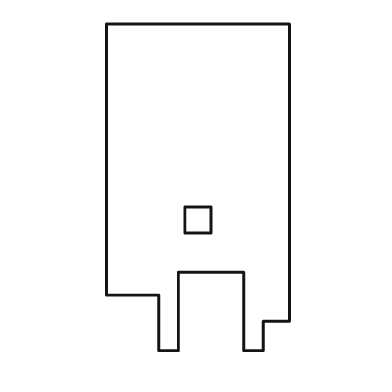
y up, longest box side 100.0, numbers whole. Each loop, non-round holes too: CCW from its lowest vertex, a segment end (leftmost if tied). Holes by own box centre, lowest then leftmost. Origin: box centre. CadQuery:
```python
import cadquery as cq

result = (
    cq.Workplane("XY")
    .moveTo(-12.0, -50.0)
    .lineTo(-6.0, -50.0)
    .lineTo(-6.0, -26.0)
    .lineTo(14.0, -26.0)
    .lineTo(14.0, -50.0)
    .lineTo(20.0, -50.0)
    .lineTo(20.0, -41.0)
    .lineTo(28.0, -41.0)
    .lineTo(28.0, 50.0)
    .lineTo(-28.0, 50.0)
    .lineTo(-28.0, -33.0)
    .lineTo(-12.0, -33.0)
    .close()
    .moveTo(-4.0, -14.0)
    .lineTo(4.0, -14.0)
    .lineTo(4.0, -6.0)
    .lineTo(-4.0, -6.0)
    .close()
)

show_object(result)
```